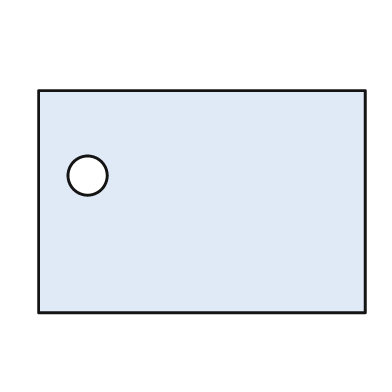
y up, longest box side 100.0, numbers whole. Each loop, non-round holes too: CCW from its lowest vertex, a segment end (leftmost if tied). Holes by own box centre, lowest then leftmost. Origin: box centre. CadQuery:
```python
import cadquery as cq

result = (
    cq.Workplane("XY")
    .moveTo(-50.0, -34.0)
    .lineTo(50.0, -34.0)
    .lineTo(50.0, 34.0)
    .lineTo(-50.0, 34.0)
    .close()
    .moveTo(-35.0, 8.0)
    .circle(6.0)
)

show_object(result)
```